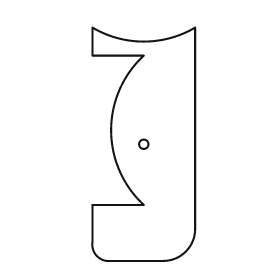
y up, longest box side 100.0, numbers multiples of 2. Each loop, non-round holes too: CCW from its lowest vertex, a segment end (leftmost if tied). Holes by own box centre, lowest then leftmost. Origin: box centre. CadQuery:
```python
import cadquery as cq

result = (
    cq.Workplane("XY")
    .moveTo(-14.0, -50.0)
    .lineTo(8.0, -50.0)
    .threePointArc((18.0, -46.0), (22.0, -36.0))
    .lineTo(22.0, 50.0)
    .threePointArc((0.0, 44.0), (-22.0, 50.0))
    .lineTo(-22.0, 38.0)
    .lineTo(0.0, 38.0)
    .threePointArc((-14.0, 6.0), (0.0, -26.0))
    .lineTo(-22.0, -26.0)
    .lineTo(-22.0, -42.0)
    .threePointArc((-20.0, -48.0), (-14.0, -50.0))
    .close()
    .moveTo(0.0, 0.0)
    .circle(2.0)
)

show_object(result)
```